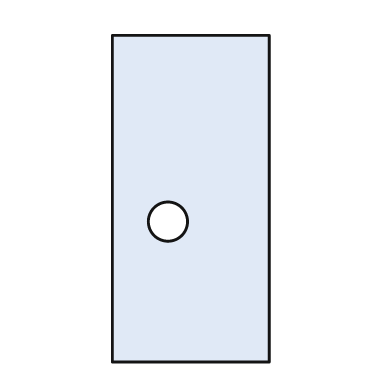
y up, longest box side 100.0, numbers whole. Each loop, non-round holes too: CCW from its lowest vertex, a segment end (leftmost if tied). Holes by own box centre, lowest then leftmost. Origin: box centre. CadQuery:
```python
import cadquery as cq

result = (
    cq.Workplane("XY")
    .moveTo(-24.0, -50.0)
    .lineTo(24.0, -50.0)
    .lineTo(24.0, 50.0)
    .lineTo(-24.0, 50.0)
    .close()
    .moveTo(-7.0, -7.0)
    .circle(6.0)
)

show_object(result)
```